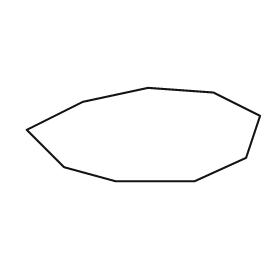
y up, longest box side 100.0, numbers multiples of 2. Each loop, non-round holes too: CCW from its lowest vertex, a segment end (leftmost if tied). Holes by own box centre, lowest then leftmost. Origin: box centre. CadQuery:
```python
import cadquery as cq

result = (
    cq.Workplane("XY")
    .moveTo(-12.0, -20.0)
    .lineTo(22.0, -20.0)
    .lineTo(44.0, -10.0)
    .lineTo(50.0, 8.0)
    .lineTo(30.0, 18.0)
    .lineTo(2.0, 20.0)
    .lineTo(-26.0, 14.0)
    .lineTo(-50.0, 2.0)
    .lineTo(-34.0, -14.0)
    .close()
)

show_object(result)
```